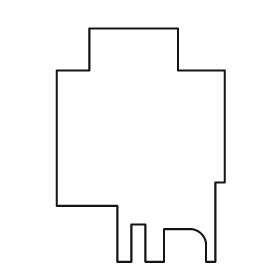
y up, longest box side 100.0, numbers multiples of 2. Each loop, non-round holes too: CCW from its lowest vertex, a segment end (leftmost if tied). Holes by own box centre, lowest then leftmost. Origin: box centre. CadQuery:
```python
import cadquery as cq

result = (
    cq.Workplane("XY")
    .moveTo(-10.0, -50.0)
    .lineTo(-4.0, -50.0)
    .lineTo(-4.0, -34.0)
    .lineTo(2.0, -34.0)
    .lineTo(2.0, -50.0)
    .lineTo(10.0, -50.0)
    .lineTo(10.0, -36.0)
    .lineTo(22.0, -36.0)
    .threePointArc((26.0, -38.0), (28.0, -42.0))
    .lineTo(28.0, -50.0)
    .lineTo(32.0, -50.0)
    .lineTo(32.0, -16.0)
    .lineTo(36.0, -16.0)
    .lineTo(36.0, 32.0)
    .lineTo(16.0, 32.0)
    .lineTo(16.0, 50.0)
    .lineTo(-22.0, 50.0)
    .lineTo(-22.0, 32.0)
    .lineTo(-36.0, 32.0)
    .lineTo(-36.0, -26.0)
    .lineTo(-10.0, -26.0)
    .close()
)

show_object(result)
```